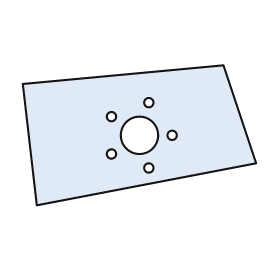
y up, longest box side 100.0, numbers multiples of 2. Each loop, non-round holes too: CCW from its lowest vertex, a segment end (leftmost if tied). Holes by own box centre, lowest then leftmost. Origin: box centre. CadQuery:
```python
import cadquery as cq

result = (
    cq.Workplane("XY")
    .moveTo(-44.0, -30.0)
    .lineTo(50.0, -12.0)
    .lineTo(36.0, 30.0)
    .lineTo(-50.0, 22.0)
    .close()
    .moveTo(4.0, -14.0)
    .circle(2.0)
    .moveTo(-12.0, -8.0)
    .circle(2.0)
    .moveTo(0.0, 0.0)
    .circle(8.0)
    .moveTo(14.0, 0.0)
    .circle(2.0)
    .moveTo(-12.0, 8.0)
    .circle(2.0)
    .moveTo(4.0, 14.0)
    .circle(2.0)
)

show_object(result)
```